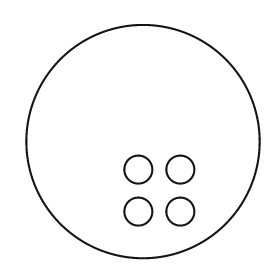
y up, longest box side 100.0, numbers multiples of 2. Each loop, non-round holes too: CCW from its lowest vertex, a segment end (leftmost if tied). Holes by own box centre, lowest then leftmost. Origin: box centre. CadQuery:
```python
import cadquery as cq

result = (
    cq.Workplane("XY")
    .moveTo(0.0, 0.0)
    .circle(50.0)
    .moveTo(-2.0, -30.0)
    .circle(6.0)
    .moveTo(16.0, -30.0)
    .circle(6.0)
    .moveTo(-2.0, -12.0)
    .circle(6.0)
    .moveTo(16.0, -12.0)
    .circle(6.0)
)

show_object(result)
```